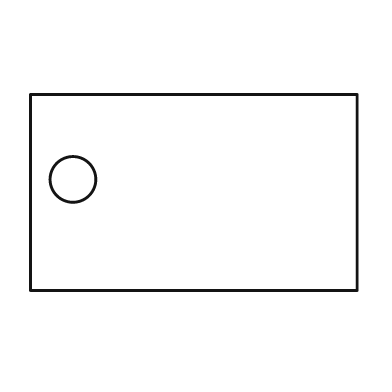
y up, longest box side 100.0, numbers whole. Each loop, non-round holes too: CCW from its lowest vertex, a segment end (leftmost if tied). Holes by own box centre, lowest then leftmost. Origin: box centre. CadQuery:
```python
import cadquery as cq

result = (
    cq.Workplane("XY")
    .moveTo(-50.0, -30.0)
    .lineTo(50.0, -30.0)
    .lineTo(50.0, 30.0)
    .lineTo(-50.0, 30.0)
    .close()
    .moveTo(-37.0, 4.0)
    .circle(7.0)
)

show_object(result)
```